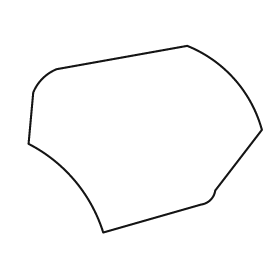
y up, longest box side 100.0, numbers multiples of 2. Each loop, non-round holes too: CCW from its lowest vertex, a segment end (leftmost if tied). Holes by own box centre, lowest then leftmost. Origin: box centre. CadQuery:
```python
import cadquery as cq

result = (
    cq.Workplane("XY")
    .moveTo(-18.0, -40.0)
    .lineTo(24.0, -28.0)
    .threePointArc((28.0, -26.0), (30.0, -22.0))
    .lineTo(50.0, 4.0)
    .threePointArc((38.0, 26.0), (18.0, 40.0))
    .lineTo(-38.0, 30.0)
    .threePointArc((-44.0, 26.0), (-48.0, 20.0))
    .lineTo(-50.0, -2.0)
    .threePointArc((-30.0, -18.0), (-18.0, -40.0))
    .close()
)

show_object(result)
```